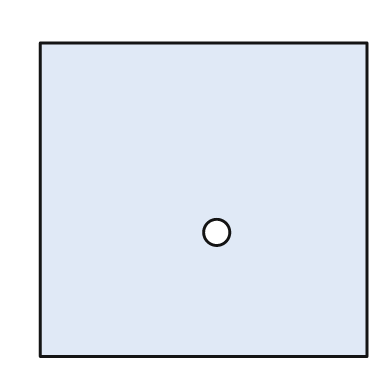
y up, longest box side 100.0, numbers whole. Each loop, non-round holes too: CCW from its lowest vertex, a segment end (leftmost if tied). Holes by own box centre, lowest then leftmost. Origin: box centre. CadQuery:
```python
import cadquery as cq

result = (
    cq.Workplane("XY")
    .moveTo(-50.0, -48.0)
    .lineTo(50.0, -48.0)
    .lineTo(50.0, 48.0)
    .lineTo(-50.0, 48.0)
    .close()
    .moveTo(4.0, -10.0)
    .circle(4.0)
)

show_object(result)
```